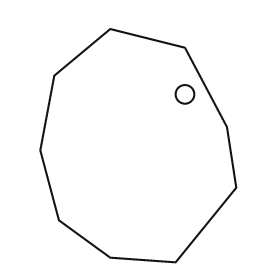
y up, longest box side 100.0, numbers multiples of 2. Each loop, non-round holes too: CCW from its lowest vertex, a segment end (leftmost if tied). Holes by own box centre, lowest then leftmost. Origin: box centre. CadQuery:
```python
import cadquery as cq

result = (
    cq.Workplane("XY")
    .moveTo(16.0, -50.0)
    .lineTo(42.0, -18.0)
    .lineTo(38.0, 8.0)
    .lineTo(20.0, 42.0)
    .lineTo(-12.0, 50.0)
    .lineTo(-36.0, 30.0)
    .lineTo(-42.0, -2.0)
    .lineTo(-34.0, -32.0)
    .lineTo(-12.0, -48.0)
    .close()
    .moveTo(20.0, 22.0)
    .circle(4.0)
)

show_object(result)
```